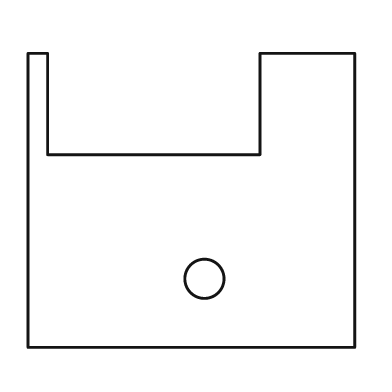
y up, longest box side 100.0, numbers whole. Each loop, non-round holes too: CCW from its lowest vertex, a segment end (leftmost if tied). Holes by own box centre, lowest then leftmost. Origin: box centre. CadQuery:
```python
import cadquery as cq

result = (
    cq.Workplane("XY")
    .moveTo(-50.0, -45.0)
    .lineTo(50.0, -45.0)
    .lineTo(50.0, 45.0)
    .lineTo(21.0, 45.0)
    .lineTo(21.0, 14.0)
    .lineTo(-44.0, 14.0)
    .lineTo(-44.0, 45.0)
    .lineTo(-50.0, 45.0)
    .close()
    .moveTo(4.0, -24.0)
    .circle(6.0)
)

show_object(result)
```